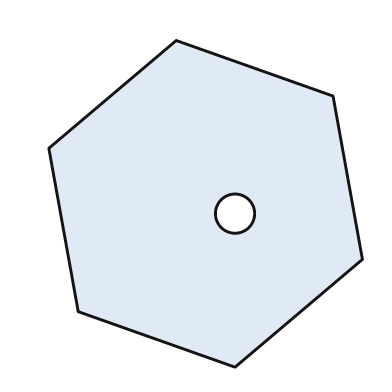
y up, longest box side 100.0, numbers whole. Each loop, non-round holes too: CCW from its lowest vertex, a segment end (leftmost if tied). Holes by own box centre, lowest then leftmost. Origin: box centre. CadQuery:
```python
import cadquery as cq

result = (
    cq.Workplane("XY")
    .moveTo(9.0, -50.0)
    .lineTo(48.0, -17.0)
    .lineTo(39.0, 33.0)
    .lineTo(-9.0, 50.0)
    .lineTo(-48.0, 17.0)
    .lineTo(-39.0, -33.0)
    .close()
    .moveTo(9.0, -3.0)
    .circle(6.0)
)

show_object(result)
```